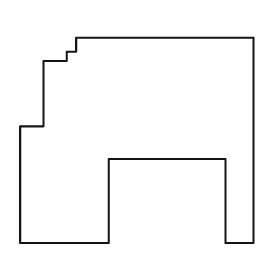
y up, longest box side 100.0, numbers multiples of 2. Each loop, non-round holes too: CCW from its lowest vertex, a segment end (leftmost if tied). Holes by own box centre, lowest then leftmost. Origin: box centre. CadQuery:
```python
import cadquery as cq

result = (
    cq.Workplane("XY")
    .moveTo(-50.0, -44.0)
    .lineTo(-12.0, -44.0)
    .lineTo(-12.0, -8.0)
    .lineTo(38.0, -8.0)
    .lineTo(38.0, -44.0)
    .lineTo(50.0, -44.0)
    .lineTo(50.0, 44.0)
    .lineTo(-26.0, 44.0)
    .lineTo(-26.0, 38.0)
    .lineTo(-30.0, 38.0)
    .lineTo(-30.0, 34.0)
    .lineTo(-40.0, 34.0)
    .lineTo(-40.0, 6.0)
    .lineTo(-50.0, 6.0)
    .close()
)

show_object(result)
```